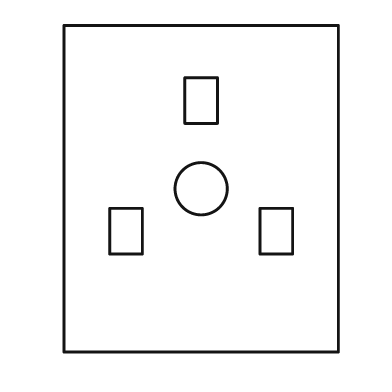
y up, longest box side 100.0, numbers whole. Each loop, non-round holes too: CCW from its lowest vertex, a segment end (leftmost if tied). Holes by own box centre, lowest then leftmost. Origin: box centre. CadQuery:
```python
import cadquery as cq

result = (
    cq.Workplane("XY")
    .moveTo(-42.0, -50.0)
    .lineTo(42.0, -50.0)
    .lineTo(42.0, 50.0)
    .lineTo(-42.0, 50.0)
    .close()
    .moveTo(-28.0, -20.0)
    .lineTo(-18.0, -20.0)
    .lineTo(-18.0, -6.0)
    .lineTo(-28.0, -6.0)
    .close()
    .moveTo(18.0, -20.0)
    .lineTo(28.0, -20.0)
    .lineTo(28.0, -6.0)
    .lineTo(18.0, -6.0)
    .close()
    .moveTo(0.0, 0.0)
    .circle(8.0)
    .moveTo(-5.0, 20.0)
    .lineTo(5.0, 20.0)
    .lineTo(5.0, 34.0)
    .lineTo(-5.0, 34.0)
    .close()
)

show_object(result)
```